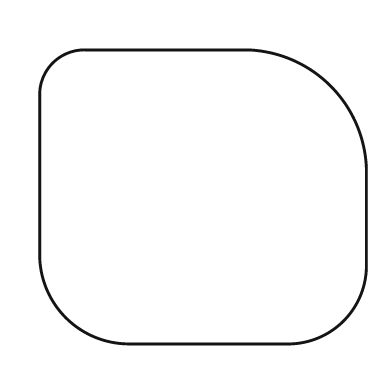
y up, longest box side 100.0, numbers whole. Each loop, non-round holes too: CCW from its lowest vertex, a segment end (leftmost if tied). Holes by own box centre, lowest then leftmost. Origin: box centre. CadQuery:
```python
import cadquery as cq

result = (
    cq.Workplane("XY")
    .moveTo(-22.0, -45.0)
    .lineTo(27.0, -45.0)
    .threePointArc((43.0, -38.0), (50.0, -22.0))
    .lineTo(50.0, 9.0)
    .threePointArc((39.0, 34.0), (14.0, 45.0))
    .lineTo(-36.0, 45.0)
    .threePointArc((-46.0, 41.0), (-50.0, 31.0))
    .lineTo(-50.0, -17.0)
    .threePointArc((-42.0, -37.0), (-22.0, -45.0))
    .close()
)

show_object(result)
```